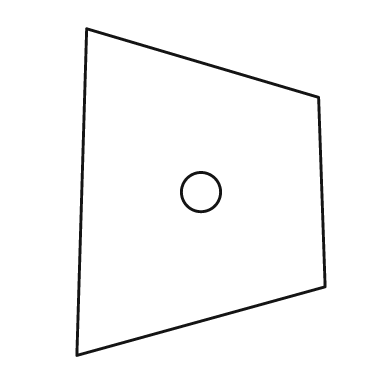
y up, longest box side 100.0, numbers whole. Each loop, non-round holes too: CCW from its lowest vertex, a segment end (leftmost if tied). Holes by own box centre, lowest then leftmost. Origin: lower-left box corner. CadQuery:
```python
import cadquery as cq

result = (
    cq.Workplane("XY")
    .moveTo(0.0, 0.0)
    .lineTo(76.0, 21.0)
    .lineTo(74.0, 79.0)
    .lineTo(3.0, 100.0)
    .close()
    .moveTo(38.0, 50.0)
    .circle(6.0)
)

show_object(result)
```